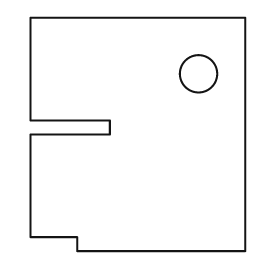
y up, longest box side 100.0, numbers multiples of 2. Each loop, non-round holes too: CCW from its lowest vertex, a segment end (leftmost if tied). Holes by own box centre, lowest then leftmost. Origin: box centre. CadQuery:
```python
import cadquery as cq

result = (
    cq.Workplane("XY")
    .moveTo(-26.0, -50.0)
    .lineTo(46.0, -50.0)
    .lineTo(46.0, 50.0)
    .lineTo(-46.0, 50.0)
    .lineTo(-46.0, 6.0)
    .lineTo(-12.0, 6.0)
    .lineTo(-12.0, 0.0)
    .lineTo(-46.0, 0.0)
    .lineTo(-46.0, -44.0)
    .lineTo(-26.0, -44.0)
    .close()
    .moveTo(26.0, 26.0)
    .circle(8.0)
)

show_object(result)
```